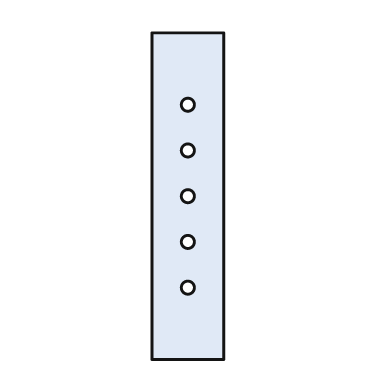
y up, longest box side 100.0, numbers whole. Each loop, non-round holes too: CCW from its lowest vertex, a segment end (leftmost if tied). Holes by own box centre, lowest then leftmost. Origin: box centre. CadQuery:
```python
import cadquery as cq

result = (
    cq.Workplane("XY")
    .moveTo(-11.0, -50.0)
    .lineTo(11.0, -50.0)
    .lineTo(11.0, 50.0)
    .lineTo(-11.0, 50.0)
    .close()
    .moveTo(0.0, -28.0)
    .circle(2.0)
    .moveTo(0.0, -14.0)
    .circle(2.0)
    .moveTo(0.0, 0.0)
    .circle(2.0)
    .moveTo(0.0, 14.0)
    .circle(2.0)
    .moveTo(0.0, 28.0)
    .circle(2.0)
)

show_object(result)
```